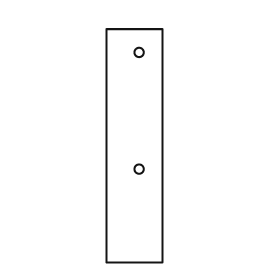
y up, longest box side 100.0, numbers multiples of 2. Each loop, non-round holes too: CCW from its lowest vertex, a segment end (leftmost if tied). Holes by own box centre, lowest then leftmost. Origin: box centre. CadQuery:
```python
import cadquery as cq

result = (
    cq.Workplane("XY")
    .moveTo(-12.0, -50.0)
    .lineTo(12.0, -50.0)
    .lineTo(12.0, 50.0)
    .lineTo(-12.0, 50.0)
    .close()
    .moveTo(2.0, -10.0)
    .circle(2.0)
    .moveTo(2.0, 40.0)
    .circle(2.0)
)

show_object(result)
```